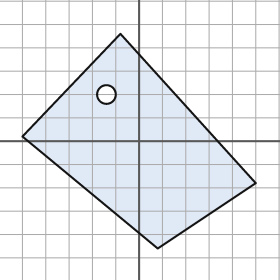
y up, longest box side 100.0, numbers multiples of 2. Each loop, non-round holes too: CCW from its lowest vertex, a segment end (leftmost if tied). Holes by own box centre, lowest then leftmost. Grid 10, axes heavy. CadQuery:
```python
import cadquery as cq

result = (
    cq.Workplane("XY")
    .moveTo(8.0, -46.0)
    .lineTo(50.0, -18.0)
    .lineTo(-8.0, 46.0)
    .lineTo(-50.0, 2.0)
    .close()
    .moveTo(-14.0, 20.0)
    .circle(4.0)
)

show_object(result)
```